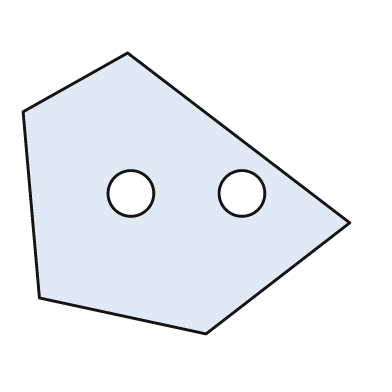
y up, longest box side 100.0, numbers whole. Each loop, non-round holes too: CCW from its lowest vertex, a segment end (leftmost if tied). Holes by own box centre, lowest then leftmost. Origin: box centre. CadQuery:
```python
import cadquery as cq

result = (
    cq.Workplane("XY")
    .moveTo(6.0, -43.0)
    .lineTo(50.0, -9.0)
    .lineTo(-18.0, 43.0)
    .lineTo(-50.0, 25.0)
    .lineTo(-45.0, -32.0)
    .close()
    .moveTo(-17.0, 0.0)
    .circle(7.0)
    .moveTo(17.0, 0.0)
    .circle(7.0)
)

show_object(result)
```